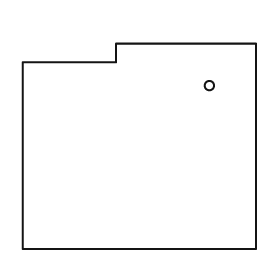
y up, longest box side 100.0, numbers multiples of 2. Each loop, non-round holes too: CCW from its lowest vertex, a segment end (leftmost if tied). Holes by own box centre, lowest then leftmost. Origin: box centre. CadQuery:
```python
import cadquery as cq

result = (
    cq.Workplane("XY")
    .moveTo(-50.0, -44.0)
    .lineTo(50.0, -44.0)
    .lineTo(50.0, 44.0)
    .lineTo(-10.0, 44.0)
    .lineTo(-10.0, 36.0)
    .lineTo(-50.0, 36.0)
    .close()
    .moveTo(30.0, 26.0)
    .circle(2.0)
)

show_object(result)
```